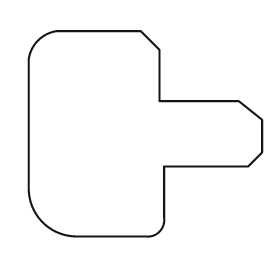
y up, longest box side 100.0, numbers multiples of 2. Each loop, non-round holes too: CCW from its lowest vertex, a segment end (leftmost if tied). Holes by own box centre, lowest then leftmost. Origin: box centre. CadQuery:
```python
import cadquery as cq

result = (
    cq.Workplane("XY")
    .moveTo(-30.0, -44.0)
    .lineTo(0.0, -44.0)
    .threePointArc((6.0, -42.0), (8.0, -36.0))
    .lineTo(8.0, -14.0)
    .lineTo(44.0, -14.0)
    .lineTo(50.0, -8.0)
    .lineTo(50.0, 6.0)
    .lineTo(40.0, 14.0)
    .lineTo(6.0, 14.0)
    .lineTo(6.0, 36.0)
    .lineTo(-2.0, 44.0)
    .lineTo(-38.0, 44.0)
    .threePointArc((-46.0, 40.0), (-50.0, 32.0))
    .lineTo(-50.0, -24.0)
    .threePointArc((-44.0, -38.0), (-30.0, -44.0))
    .close()
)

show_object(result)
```